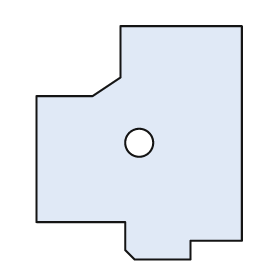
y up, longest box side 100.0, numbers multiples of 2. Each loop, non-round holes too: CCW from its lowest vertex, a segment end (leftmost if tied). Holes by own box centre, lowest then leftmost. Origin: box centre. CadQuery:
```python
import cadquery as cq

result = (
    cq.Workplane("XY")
    .moveTo(-2.0, -50.0)
    .lineTo(22.0, -50.0)
    .lineTo(22.0, -42.0)
    .lineTo(44.0, -42.0)
    .lineTo(44.0, 50.0)
    .lineTo(-8.0, 50.0)
    .lineTo(-8.0, 28.0)
    .lineTo(-20.0, 20.0)
    .lineTo(-44.0, 20.0)
    .lineTo(-44.0, -34.0)
    .lineTo(-6.0, -34.0)
    .lineTo(-6.0, -46.0)
    .close()
    .moveTo(0.0, 0.0)
    .circle(6.0)
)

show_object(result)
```